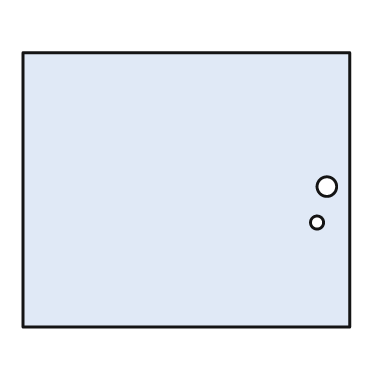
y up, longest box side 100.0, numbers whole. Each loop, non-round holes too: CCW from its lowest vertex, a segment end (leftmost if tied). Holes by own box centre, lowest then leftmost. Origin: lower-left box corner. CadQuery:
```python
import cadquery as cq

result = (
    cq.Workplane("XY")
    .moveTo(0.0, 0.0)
    .lineTo(100.0, 0.0)
    .lineTo(100.0, 84.0)
    .lineTo(0.0, 84.0)
    .close()
    .moveTo(90.0, 32.0)
    .circle(2.0)
    .moveTo(93.0, 43.0)
    .circle(3.0)
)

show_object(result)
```